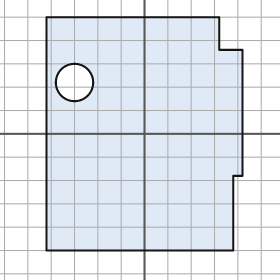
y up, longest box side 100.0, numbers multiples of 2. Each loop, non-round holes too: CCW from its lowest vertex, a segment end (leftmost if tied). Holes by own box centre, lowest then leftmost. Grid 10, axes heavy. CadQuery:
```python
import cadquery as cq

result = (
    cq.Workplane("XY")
    .moveTo(-42.0, -50.0)
    .lineTo(38.0, -50.0)
    .lineTo(38.0, -18.0)
    .lineTo(42.0, -18.0)
    .lineTo(42.0, 36.0)
    .lineTo(32.0, 36.0)
    .lineTo(32.0, 50.0)
    .lineTo(-42.0, 50.0)
    .close()
    .moveTo(-30.0, 22.0)
    .circle(8.0)
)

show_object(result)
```